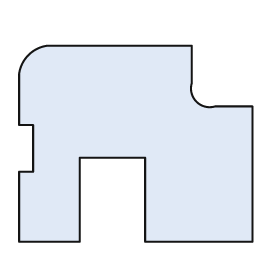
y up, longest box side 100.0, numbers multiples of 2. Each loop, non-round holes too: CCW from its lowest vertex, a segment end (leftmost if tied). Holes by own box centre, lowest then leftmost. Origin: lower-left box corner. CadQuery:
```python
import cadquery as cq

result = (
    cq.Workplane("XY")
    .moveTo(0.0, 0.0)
    .lineTo(26.0, 0.0)
    .lineTo(26.0, 36.0)
    .lineTo(54.0, 36.0)
    .lineTo(54.0, 0.0)
    .lineTo(100.0, 0.0)
    .lineTo(100.0, 58.0)
    .lineTo(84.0, 58.0)
    .threePointArc((76.0, 60.0), (74.0, 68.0))
    .lineTo(74.0, 84.0)
    .lineTo(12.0, 84.0)
    .threePointArc((4.0, 80.0), (0.0, 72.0))
    .lineTo(0.0, 50.0)
    .lineTo(6.0, 50.0)
    .lineTo(6.0, 30.0)
    .lineTo(0.0, 30.0)
    .close()
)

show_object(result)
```